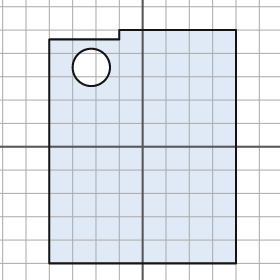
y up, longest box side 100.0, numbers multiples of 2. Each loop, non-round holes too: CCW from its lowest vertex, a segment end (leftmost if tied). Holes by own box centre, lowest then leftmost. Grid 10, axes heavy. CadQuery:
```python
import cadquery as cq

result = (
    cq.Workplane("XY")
    .moveTo(-40.0, -50.0)
    .lineTo(40.0, -50.0)
    .lineTo(40.0, 50.0)
    .lineTo(-10.0, 50.0)
    .lineTo(-10.0, 46.0)
    .lineTo(-40.0, 46.0)
    .close()
    .moveTo(-22.0, 34.0)
    .circle(8.0)
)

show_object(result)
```